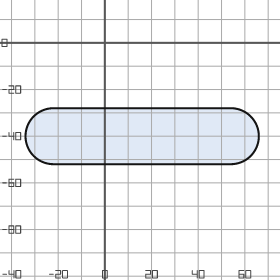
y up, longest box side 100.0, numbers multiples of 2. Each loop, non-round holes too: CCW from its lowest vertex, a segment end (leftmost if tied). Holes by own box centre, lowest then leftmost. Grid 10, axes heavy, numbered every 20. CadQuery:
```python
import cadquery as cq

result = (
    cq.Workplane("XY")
    .moveTo(-22.0, -52.0)
    .lineTo(54.0, -52.0)
    .threePointArc((66.0, -40.0), (54.0, -28.0))
    .lineTo(-22.0, -28.0)
    .threePointArc((-34.0, -40.0), (-22.0, -52.0))
    .close()
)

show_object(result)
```